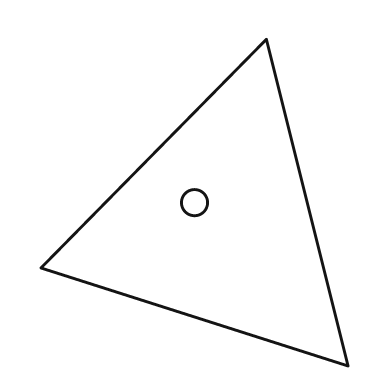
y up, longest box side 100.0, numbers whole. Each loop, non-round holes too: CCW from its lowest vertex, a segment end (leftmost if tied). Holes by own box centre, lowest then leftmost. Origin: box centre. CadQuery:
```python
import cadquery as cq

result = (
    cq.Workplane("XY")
    .moveTo(47.0, -50.0)
    .lineTo(22.0, 50.0)
    .lineTo(-47.0, -20.0)
    .close()
    .moveTo(0.0, 0.0)
    .circle(4.0)
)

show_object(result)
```